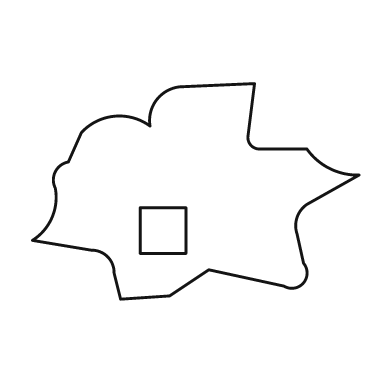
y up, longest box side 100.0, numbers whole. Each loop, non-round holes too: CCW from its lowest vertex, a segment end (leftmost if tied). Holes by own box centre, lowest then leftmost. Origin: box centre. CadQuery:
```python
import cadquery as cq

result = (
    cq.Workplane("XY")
    .moveTo(-23.0, -33.0)
    .lineTo(-8.0, -32.0)
    .lineTo(4.0, -24.0)
    .lineTo(27.0, -29.0)
    .threePointArc((33.0, -28.0), (33.0, -22.0))
    .lineTo(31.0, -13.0)
    .threePointArc((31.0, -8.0), (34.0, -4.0))
    .lineTo(50.0, 5.0)
    .threePointArc((41.0, 7.0), (34.0, 13.0))
    .lineTo(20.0, 13.0)
    .threePointArc((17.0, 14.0), (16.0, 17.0))
    .lineTo(18.0, 33.0)
    .lineTo(-5.0, 32.0)
    .threePointArc((-12.0, 28.0), (-14.0, 20.0))
    .threePointArc((-25.0, 23.0), (-35.0, 18.0))
    .lineTo(-39.0, 9.0)
    .threePointArc((-43.0, 6.0), (-43.0, 1.0))
    .threePointArc((-44.0, -8.0), (-50.0, -15.0))
    .lineTo(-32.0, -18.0)
    .threePointArc((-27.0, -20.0), (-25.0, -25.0))
    .close()
    .moveTo(-17.0, -19.0)
    .lineTo(-3.0, -19.0)
    .lineTo(-3.0, -5.0)
    .lineTo(-17.0, -5.0)
    .close()
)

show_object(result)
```